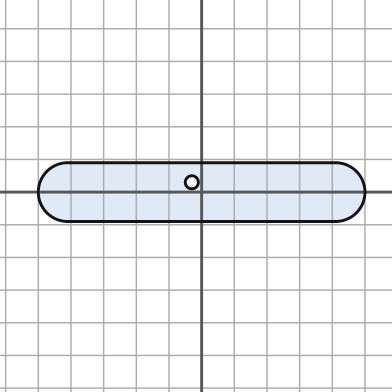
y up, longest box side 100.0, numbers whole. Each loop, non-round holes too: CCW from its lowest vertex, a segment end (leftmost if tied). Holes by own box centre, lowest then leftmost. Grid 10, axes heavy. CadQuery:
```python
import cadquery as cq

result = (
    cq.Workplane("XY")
    .moveTo(-41.0, -9.0)
    .lineTo(41.0, -9.0)
    .threePointArc((50.0, 0.0), (41.0, 9.0))
    .lineTo(-41.0, 9.0)
    .threePointArc((-50.0, 0.0), (-41.0, -9.0))
    .close()
    .moveTo(-3.0, 3.0)
    .circle(2.0)
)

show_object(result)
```